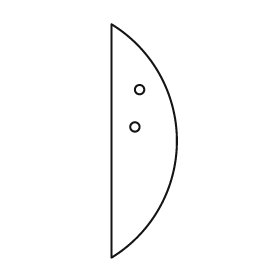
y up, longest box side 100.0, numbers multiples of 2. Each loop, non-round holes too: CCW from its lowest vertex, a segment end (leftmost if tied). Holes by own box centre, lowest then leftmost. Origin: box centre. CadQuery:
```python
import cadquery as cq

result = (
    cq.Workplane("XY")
    .moveTo(-14.0, -50.0)
    .threePointArc((14.0, 0.0), (-14.0, 50.0))
    .close()
    .moveTo(-4.0, 6.0)
    .circle(2.0)
    .moveTo(-2.0, 22.0)
    .circle(2.0)
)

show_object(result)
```